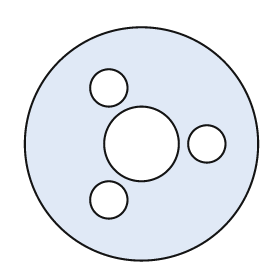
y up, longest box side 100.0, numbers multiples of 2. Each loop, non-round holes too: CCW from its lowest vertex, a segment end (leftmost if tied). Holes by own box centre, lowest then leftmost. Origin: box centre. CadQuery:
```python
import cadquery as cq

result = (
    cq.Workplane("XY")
    .moveTo(0.0, 0.0)
    .circle(50.0)
    .moveTo(-14.0, -24.0)
    .circle(8.0)
    .moveTo(0.0, 0.0)
    .circle(16.0)
    .moveTo(28.0, 0.0)
    .circle(8.0)
    .moveTo(-14.0, 24.0)
    .circle(8.0)
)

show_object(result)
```